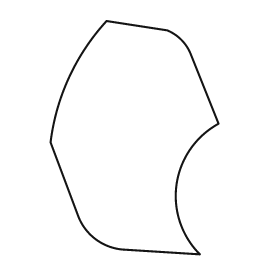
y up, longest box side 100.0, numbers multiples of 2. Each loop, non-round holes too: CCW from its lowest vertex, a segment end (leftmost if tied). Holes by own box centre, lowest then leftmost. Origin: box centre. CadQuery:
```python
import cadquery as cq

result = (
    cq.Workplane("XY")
    .moveTo(28.0, -50.0)
    .threePointArc((18.0, -20.0), (36.0, 6.0))
    .lineTo(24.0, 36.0)
    .threePointArc((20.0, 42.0), (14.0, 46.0))
    .lineTo(-12.0, 50.0)
    .threePointArc((-28.0, 26.0), (-36.0, -2.0))
    .lineTo(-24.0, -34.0)
    .threePointArc((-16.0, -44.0), (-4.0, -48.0))
    .close()
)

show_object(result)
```